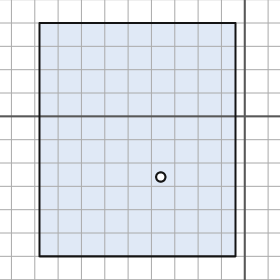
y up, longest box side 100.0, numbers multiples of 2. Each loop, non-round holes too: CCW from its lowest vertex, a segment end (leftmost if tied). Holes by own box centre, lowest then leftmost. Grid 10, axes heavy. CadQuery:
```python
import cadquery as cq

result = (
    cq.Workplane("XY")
    .moveTo(-88.0, -60.0)
    .lineTo(-4.0, -60.0)
    .lineTo(-4.0, 40.0)
    .lineTo(-88.0, 40.0)
    .close()
    .moveTo(-36.0, -26.0)
    .circle(2.0)
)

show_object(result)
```